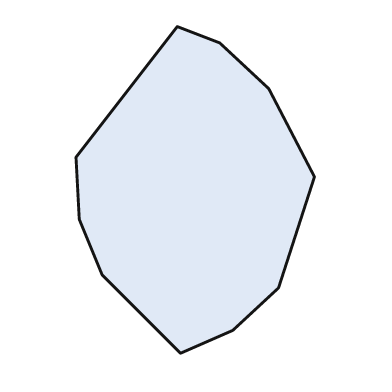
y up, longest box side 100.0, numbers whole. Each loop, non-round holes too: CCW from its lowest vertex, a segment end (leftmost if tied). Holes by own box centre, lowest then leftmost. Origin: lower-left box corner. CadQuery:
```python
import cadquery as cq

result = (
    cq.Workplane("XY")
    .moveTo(32.0, 0.0)
    .lineTo(48.0, 7.0)
    .lineTo(62.0, 20.0)
    .lineTo(73.0, 54.0)
    .lineTo(59.0, 81.0)
    .lineTo(44.0, 95.0)
    .lineTo(31.0, 100.0)
    .lineTo(0.0, 60.0)
    .lineTo(1.0, 41.0)
    .lineTo(8.0, 24.0)
    .close()
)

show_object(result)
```